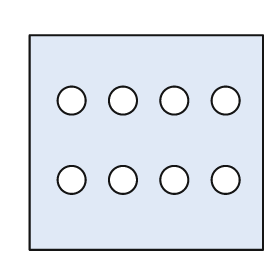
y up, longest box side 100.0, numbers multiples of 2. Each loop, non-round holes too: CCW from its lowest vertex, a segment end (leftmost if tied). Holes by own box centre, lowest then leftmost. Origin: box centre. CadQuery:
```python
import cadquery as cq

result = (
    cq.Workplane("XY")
    .moveTo(-50.0, -46.0)
    .lineTo(50.0, -46.0)
    .lineTo(50.0, 46.0)
    .lineTo(-50.0, 46.0)
    .close()
    .moveTo(-32.0, -16.0)
    .circle(6.0)
    .moveTo(-10.0, -16.0)
    .circle(6.0)
    .moveTo(12.0, -16.0)
    .circle(6.0)
    .moveTo(34.0, -16.0)
    .circle(6.0)
    .moveTo(-32.0, 18.0)
    .circle(6.0)
    .moveTo(-10.0, 18.0)
    .circle(6.0)
    .moveTo(12.0, 18.0)
    .circle(6.0)
    .moveTo(34.0, 18.0)
    .circle(6.0)
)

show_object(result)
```